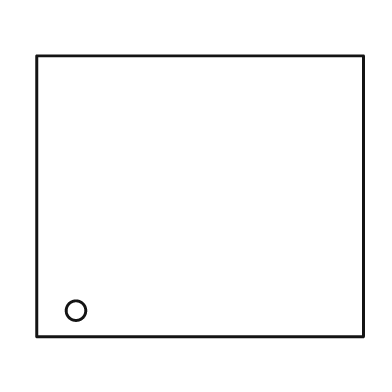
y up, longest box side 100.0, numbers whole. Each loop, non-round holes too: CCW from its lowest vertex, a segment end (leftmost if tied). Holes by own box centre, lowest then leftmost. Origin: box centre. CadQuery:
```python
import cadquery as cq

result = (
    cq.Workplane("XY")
    .moveTo(-50.0, -43.0)
    .lineTo(50.0, -43.0)
    .lineTo(50.0, 43.0)
    .lineTo(-50.0, 43.0)
    .close()
    .moveTo(-38.0, -35.0)
    .circle(3.0)
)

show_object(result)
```